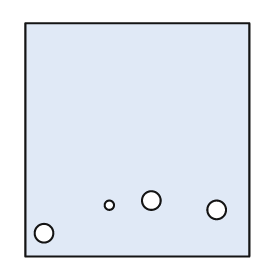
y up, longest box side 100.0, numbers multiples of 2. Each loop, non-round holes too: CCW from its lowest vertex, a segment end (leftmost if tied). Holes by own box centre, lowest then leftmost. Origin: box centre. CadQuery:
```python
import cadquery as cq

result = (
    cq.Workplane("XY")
    .moveTo(-48.0, -50.0)
    .lineTo(48.0, -50.0)
    .lineTo(48.0, 50.0)
    .lineTo(-48.0, 50.0)
    .close()
    .moveTo(-40.0, -40.0)
    .circle(4.0)
    .moveTo(34.0, -30.0)
    .circle(4.0)
    .moveTo(-12.0, -28.0)
    .circle(2.0)
    .moveTo(6.0, -26.0)
    .circle(4.0)
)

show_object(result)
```